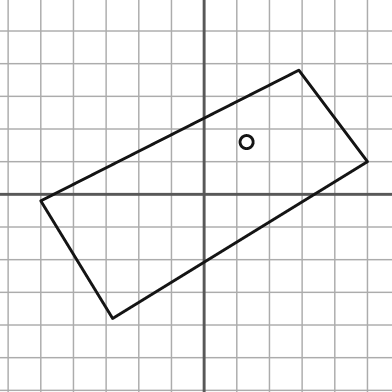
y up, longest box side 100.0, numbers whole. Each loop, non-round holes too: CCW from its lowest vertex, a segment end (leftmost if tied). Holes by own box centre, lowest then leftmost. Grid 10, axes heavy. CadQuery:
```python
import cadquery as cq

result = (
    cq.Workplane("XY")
    .moveTo(-28.0, -38.0)
    .lineTo(50.0, 10.0)
    .lineTo(29.0, 38.0)
    .lineTo(-50.0, -2.0)
    .close()
    .moveTo(13.0, 16.0)
    .circle(2.0)
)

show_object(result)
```